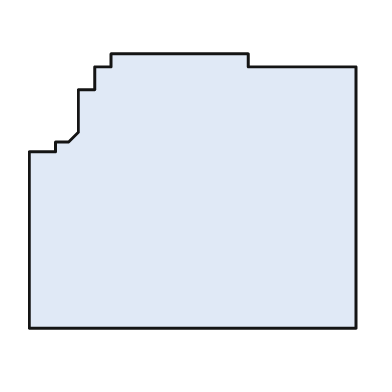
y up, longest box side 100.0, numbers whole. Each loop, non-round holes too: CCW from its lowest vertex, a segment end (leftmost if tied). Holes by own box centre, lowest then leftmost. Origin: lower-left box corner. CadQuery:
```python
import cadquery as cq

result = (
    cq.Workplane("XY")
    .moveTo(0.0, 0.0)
    .lineTo(100.0, 0.0)
    .lineTo(100.0, 80.0)
    .lineTo(67.0, 80.0)
    .lineTo(67.0, 84.0)
    .lineTo(25.0, 84.0)
    .lineTo(25.0, 80.0)
    .lineTo(20.0, 80.0)
    .lineTo(20.0, 73.0)
    .lineTo(15.0, 73.0)
    .lineTo(15.0, 60.0)
    .lineTo(12.0, 57.0)
    .lineTo(8.0, 57.0)
    .lineTo(8.0, 54.0)
    .lineTo(0.0, 54.0)
    .close()
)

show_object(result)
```